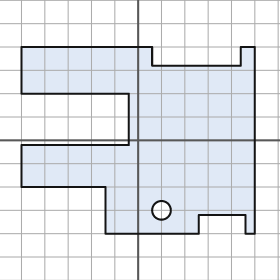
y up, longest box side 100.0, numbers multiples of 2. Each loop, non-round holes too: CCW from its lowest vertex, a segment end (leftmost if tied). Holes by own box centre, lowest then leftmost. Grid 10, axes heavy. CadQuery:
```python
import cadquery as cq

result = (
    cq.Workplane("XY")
    .moveTo(-14.0, -40.0)
    .lineTo(26.0, -40.0)
    .lineTo(26.0, -32.0)
    .lineTo(46.0, -32.0)
    .lineTo(46.0, -40.0)
    .lineTo(50.0, -40.0)
    .lineTo(50.0, 40.0)
    .lineTo(44.0, 40.0)
    .lineTo(44.0, 32.0)
    .lineTo(6.0, 32.0)
    .lineTo(6.0, 40.0)
    .lineTo(-50.0, 40.0)
    .lineTo(-50.0, 20.0)
    .lineTo(-4.0, 20.0)
    .lineTo(-4.0, -2.0)
    .lineTo(-50.0, -2.0)
    .lineTo(-50.0, -20.0)
    .lineTo(-14.0, -20.0)
    .close()
    .moveTo(10.0, -30.0)
    .circle(4.0)
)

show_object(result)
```